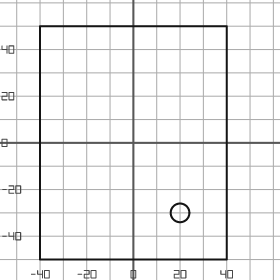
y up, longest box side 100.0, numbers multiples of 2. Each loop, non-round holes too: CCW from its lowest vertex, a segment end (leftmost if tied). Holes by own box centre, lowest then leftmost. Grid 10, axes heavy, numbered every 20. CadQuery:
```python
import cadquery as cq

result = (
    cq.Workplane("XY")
    .moveTo(-40.0, -50.0)
    .lineTo(40.0, -50.0)
    .lineTo(40.0, 50.0)
    .lineTo(-40.0, 50.0)
    .close()
    .moveTo(20.0, -30.0)
    .circle(4.0)
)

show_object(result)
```